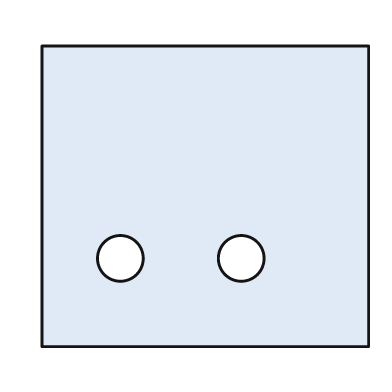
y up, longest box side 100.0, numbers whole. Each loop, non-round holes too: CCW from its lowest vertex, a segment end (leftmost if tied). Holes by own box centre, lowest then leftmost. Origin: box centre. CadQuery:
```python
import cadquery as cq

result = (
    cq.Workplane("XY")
    .moveTo(-50.0, -46.0)
    .lineTo(50.0, -46.0)
    .lineTo(50.0, 46.0)
    .lineTo(-50.0, 46.0)
    .close()
    .moveTo(-26.0, -19.0)
    .circle(7.0)
    .moveTo(11.0, -19.0)
    .circle(7.0)
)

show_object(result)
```